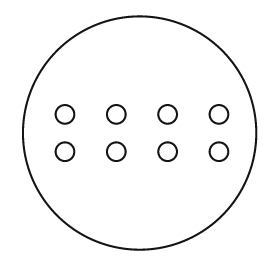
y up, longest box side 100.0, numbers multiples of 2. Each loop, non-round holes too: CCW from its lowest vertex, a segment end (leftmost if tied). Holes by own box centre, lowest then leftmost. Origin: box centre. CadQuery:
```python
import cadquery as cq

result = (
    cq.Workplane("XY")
    .moveTo(0.0, 0.0)
    .circle(50.0)
    .moveTo(-32.0, -8.0)
    .circle(4.0)
    .moveTo(-10.0, -8.0)
    .circle(4.0)
    .moveTo(12.0, -8.0)
    .circle(4.0)
    .moveTo(34.0, -8.0)
    .circle(4.0)
    .moveTo(-32.0, 8.0)
    .circle(4.0)
    .moveTo(-10.0, 8.0)
    .circle(4.0)
    .moveTo(12.0, 8.0)
    .circle(4.0)
    .moveTo(34.0, 8.0)
    .circle(4.0)
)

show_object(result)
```